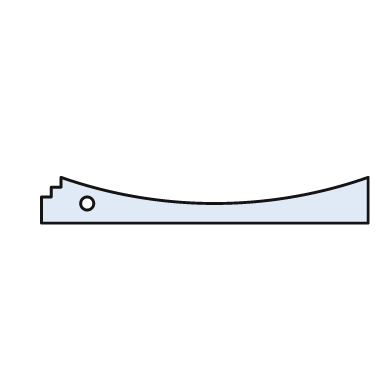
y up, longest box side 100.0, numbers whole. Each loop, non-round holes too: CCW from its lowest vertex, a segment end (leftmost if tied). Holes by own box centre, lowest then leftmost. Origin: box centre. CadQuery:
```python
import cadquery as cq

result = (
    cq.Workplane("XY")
    .moveTo(-50.0, -7.0)
    .lineTo(50.0, -7.0)
    .lineTo(50.0, 7.0)
    .threePointArc((3.0, -1.0), (-44.0, 7.0))
    .lineTo(-44.0, 4.0)
    .lineTo(-47.0, 4.0)
    .lineTo(-47.0, 1.0)
    .lineTo(-50.0, 1.0)
    .close()
    .moveTo(-36.0, -1.0)
    .circle(2.0)
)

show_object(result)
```